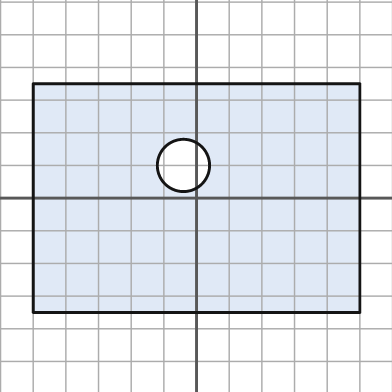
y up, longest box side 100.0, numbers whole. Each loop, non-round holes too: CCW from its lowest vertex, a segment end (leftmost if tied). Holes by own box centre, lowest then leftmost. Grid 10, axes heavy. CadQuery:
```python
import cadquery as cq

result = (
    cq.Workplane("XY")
    .moveTo(-50.0, -35.0)
    .lineTo(50.0, -35.0)
    .lineTo(50.0, 35.0)
    .lineTo(-50.0, 35.0)
    .close()
    .moveTo(-4.0, 10.0)
    .circle(8.0)
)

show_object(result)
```